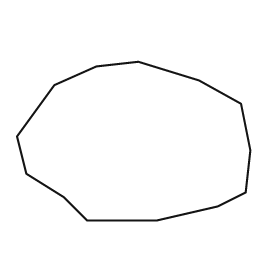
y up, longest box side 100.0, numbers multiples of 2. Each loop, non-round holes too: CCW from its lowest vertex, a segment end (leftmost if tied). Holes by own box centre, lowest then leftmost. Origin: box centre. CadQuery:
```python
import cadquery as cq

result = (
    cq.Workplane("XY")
    .moveTo(-20.0, -34.0)
    .lineTo(10.0, -34.0)
    .lineTo(36.0, -28.0)
    .lineTo(48.0, -22.0)
    .lineTo(50.0, -4.0)
    .lineTo(46.0, 16.0)
    .lineTo(28.0, 26.0)
    .lineTo(2.0, 34.0)
    .lineTo(-16.0, 32.0)
    .lineTo(-34.0, 24.0)
    .lineTo(-50.0, 2.0)
    .lineTo(-46.0, -14.0)
    .lineTo(-30.0, -24.0)
    .close()
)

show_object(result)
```